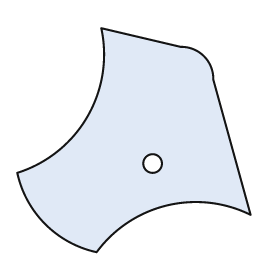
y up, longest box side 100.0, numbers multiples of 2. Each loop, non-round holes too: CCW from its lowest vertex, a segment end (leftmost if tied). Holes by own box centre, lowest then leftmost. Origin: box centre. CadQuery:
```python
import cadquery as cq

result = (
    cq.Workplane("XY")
    .moveTo(-16.0, -48.0)
    .threePointArc((14.0, -28.0), (50.0, -32.0))
    .lineTo(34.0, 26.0)
    .threePointArc((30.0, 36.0), (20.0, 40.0))
    .lineTo(-14.0, 48.0)
    .threePointArc((-20.0, 10.0), (-50.0, -14.0))
    .threePointArc((-38.0, -36.0), (-16.0, -48.0))
    .close()
    .moveTo(8.0, -10.0)
    .circle(4.0)
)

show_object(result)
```